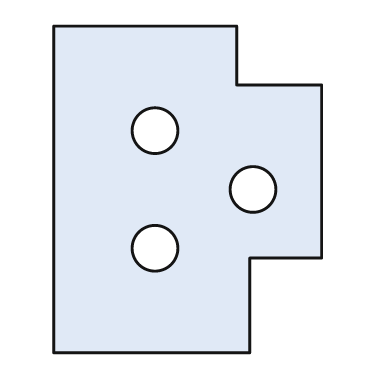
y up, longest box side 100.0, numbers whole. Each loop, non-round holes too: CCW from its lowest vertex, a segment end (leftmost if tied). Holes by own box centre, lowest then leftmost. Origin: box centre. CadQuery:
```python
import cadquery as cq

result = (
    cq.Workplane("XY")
    .moveTo(-41.0, -50.0)
    .lineTo(19.0, -50.0)
    .lineTo(19.0, -21.0)
    .lineTo(41.0, -21.0)
    .lineTo(41.0, 32.0)
    .lineTo(15.0, 32.0)
    .lineTo(15.0, 50.0)
    .lineTo(-41.0, 50.0)
    .close()
    .moveTo(-10.0, -18.0)
    .circle(7.0)
    .moveTo(20.0, 0.0)
    .circle(7.0)
    .moveTo(-10.0, 18.0)
    .circle(7.0)
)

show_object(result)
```